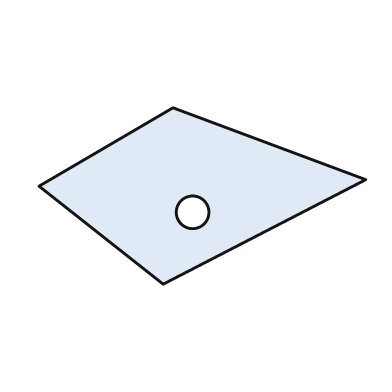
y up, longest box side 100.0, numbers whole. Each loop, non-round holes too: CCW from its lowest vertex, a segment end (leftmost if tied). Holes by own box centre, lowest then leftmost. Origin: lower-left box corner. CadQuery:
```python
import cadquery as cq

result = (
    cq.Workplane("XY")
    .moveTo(38.0, 0.0)
    .lineTo(100.0, 32.0)
    .lineTo(41.0, 54.0)
    .lineTo(0.0, 30.0)
    .close()
    .moveTo(47.0, 22.0)
    .circle(5.0)
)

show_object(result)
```